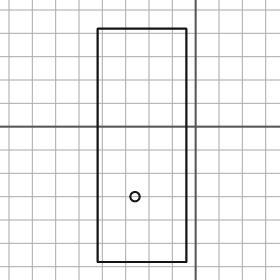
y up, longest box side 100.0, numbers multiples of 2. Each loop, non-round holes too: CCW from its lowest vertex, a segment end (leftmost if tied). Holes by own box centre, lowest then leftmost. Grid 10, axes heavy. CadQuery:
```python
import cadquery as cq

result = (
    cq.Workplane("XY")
    .moveTo(-42.0, -58.0)
    .lineTo(-4.0, -58.0)
    .lineTo(-4.0, 42.0)
    .lineTo(-42.0, 42.0)
    .close()
    .moveTo(-26.0, -30.0)
    .circle(2.0)
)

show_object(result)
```